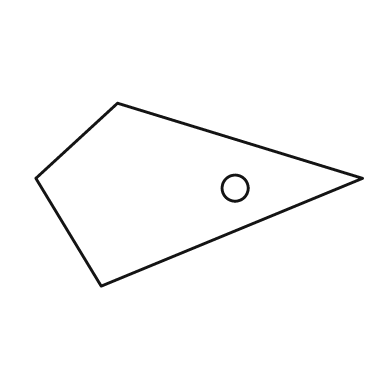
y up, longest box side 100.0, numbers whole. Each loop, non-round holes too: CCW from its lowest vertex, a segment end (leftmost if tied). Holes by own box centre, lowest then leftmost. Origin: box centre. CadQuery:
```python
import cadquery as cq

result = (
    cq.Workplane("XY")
    .moveTo(-30.0, -28.0)
    .lineTo(50.0, 5.0)
    .lineTo(-25.0, 28.0)
    .lineTo(-50.0, 5.0)
    .close()
    .moveTo(11.0, 2.0)
    .circle(4.0)
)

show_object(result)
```